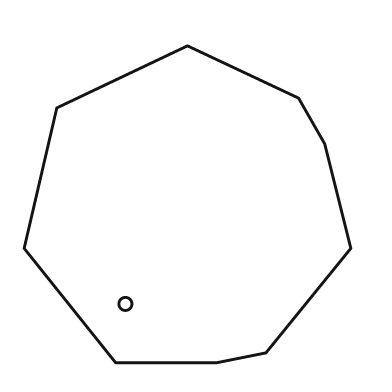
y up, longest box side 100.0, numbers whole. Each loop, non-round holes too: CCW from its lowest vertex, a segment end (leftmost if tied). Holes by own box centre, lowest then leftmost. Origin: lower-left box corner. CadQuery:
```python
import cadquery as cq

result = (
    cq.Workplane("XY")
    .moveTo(28.0, 0.0)
    .lineTo(59.0, 0.0)
    .lineTo(74.0, 3.0)
    .lineTo(100.0, 35.0)
    .lineTo(92.0, 67.0)
    .lineTo(84.0, 81.0)
    .lineTo(50.0, 97.0)
    .lineTo(10.0, 78.0)
    .lineTo(0.0, 35.0)
    .close()
    .moveTo(31.0, 18.0)
    .circle(2.0)
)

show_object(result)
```